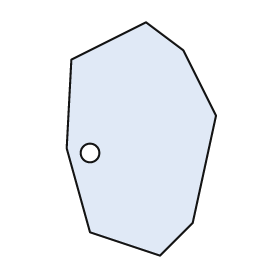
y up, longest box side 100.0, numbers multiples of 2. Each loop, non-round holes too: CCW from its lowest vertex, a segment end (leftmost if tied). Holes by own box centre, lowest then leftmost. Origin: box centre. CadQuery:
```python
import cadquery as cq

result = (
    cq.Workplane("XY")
    .moveTo(8.0, -50.0)
    .lineTo(22.0, -36.0)
    .lineTo(32.0, 10.0)
    .lineTo(18.0, 38.0)
    .lineTo(2.0, 50.0)
    .lineTo(-30.0, 34.0)
    .lineTo(-32.0, -4.0)
    .lineTo(-22.0, -40.0)
    .close()
    .moveTo(-22.0, -6.0)
    .circle(4.0)
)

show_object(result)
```